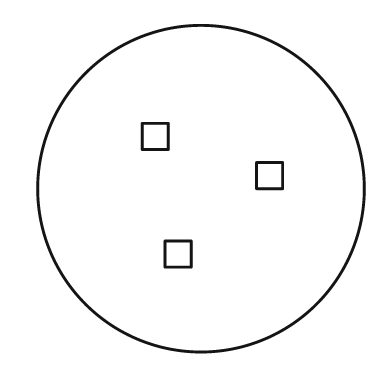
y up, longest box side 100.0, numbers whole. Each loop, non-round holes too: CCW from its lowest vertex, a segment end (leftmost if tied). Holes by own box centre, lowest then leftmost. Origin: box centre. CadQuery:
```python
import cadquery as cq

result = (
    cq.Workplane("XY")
    .moveTo(0.0, 0.0)
    .circle(50.0)
    .moveTo(-11.0, -24.0)
    .lineTo(-3.0, -24.0)
    .lineTo(-3.0, -16.0)
    .lineTo(-11.0, -16.0)
    .close()
    .moveTo(17.0, 0.0)
    .lineTo(25.0, 0.0)
    .lineTo(25.0, 8.0)
    .lineTo(17.0, 8.0)
    .close()
    .moveTo(-18.0, 12.0)
    .lineTo(-10.0, 12.0)
    .lineTo(-10.0, 20.0)
    .lineTo(-18.0, 20.0)
    .close()
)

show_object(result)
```